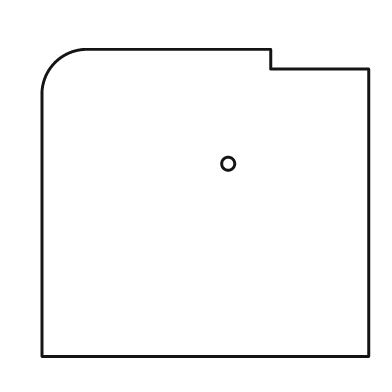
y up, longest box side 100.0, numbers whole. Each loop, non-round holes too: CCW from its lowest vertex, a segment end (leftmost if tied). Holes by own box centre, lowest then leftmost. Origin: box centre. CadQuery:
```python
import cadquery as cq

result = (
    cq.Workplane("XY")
    .moveTo(-50.0, -47.0)
    .lineTo(50.0, -47.0)
    .lineTo(50.0, 41.0)
    .lineTo(20.0, 41.0)
    .lineTo(20.0, 47.0)
    .lineTo(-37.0, 47.0)
    .threePointArc((-46.0, 43.0), (-50.0, 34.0))
    .close()
    .moveTo(7.0, 12.0)
    .circle(2.0)
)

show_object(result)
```